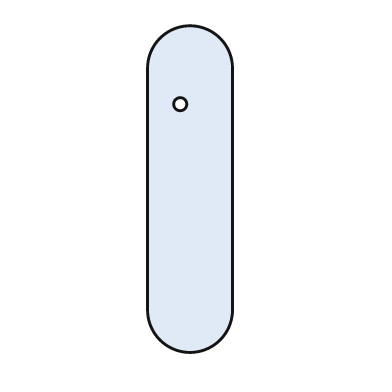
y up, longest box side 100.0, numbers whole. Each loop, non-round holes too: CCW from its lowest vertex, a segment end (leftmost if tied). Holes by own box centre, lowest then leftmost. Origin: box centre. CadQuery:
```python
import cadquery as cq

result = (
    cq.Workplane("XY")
    .moveTo(-13.0, -37.0)
    .threePointArc((0.0, -50.0), (13.0, -37.0))
    .lineTo(13.0, 37.0)
    .threePointArc((0.0, 50.0), (-13.0, 37.0))
    .close()
    .moveTo(-3.0, 26.0)
    .circle(2.0)
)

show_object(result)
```